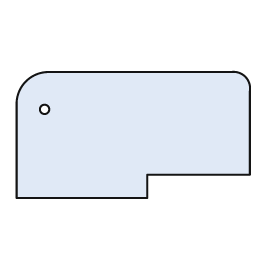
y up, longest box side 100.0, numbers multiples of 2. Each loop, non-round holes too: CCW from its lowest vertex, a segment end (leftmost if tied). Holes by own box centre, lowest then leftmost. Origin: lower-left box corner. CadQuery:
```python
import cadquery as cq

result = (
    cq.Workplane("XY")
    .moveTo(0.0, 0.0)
    .lineTo(56.0, 0.0)
    .lineTo(56.0, 10.0)
    .lineTo(100.0, 10.0)
    .lineTo(100.0, 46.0)
    .threePointArc((98.0, 52.0), (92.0, 54.0))
    .lineTo(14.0, 54.0)
    .threePointArc((4.0, 50.0), (0.0, 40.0))
    .close()
    .moveTo(12.0, 38.0)
    .circle(2.0)
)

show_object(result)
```